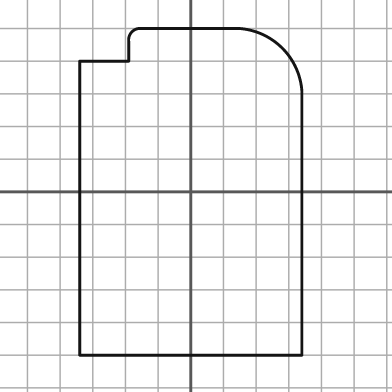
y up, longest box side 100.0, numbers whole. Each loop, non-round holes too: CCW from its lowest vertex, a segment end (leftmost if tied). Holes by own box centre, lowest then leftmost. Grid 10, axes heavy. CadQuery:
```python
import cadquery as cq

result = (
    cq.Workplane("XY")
    .moveTo(-34.0, -50.0)
    .lineTo(34.0, -50.0)
    .lineTo(34.0, 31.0)
    .threePointArc((28.0, 44.0), (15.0, 50.0))
    .lineTo(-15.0, 50.0)
    .threePointArc((-18.0, 49.0), (-19.0, 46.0))
    .lineTo(-19.0, 40.0)
    .lineTo(-34.0, 40.0)
    .close()
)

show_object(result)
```